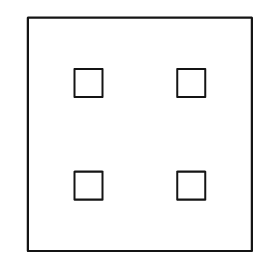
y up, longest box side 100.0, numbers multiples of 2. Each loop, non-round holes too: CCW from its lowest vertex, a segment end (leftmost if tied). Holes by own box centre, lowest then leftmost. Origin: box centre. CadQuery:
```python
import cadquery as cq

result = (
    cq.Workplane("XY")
    .moveTo(-48.0, -50.0)
    .lineTo(48.0, -50.0)
    .lineTo(48.0, 50.0)
    .lineTo(-48.0, 50.0)
    .close()
    .moveTo(-28.0, -28.0)
    .lineTo(-16.0, -28.0)
    .lineTo(-16.0, -16.0)
    .lineTo(-28.0, -16.0)
    .close()
    .moveTo(16.0, -28.0)
    .lineTo(28.0, -28.0)
    .lineTo(28.0, -16.0)
    .lineTo(16.0, -16.0)
    .close()
    .moveTo(-28.0, 16.0)
    .lineTo(-16.0, 16.0)
    .lineTo(-16.0, 28.0)
    .lineTo(-28.0, 28.0)
    .close()
    .moveTo(16.0, 16.0)
    .lineTo(28.0, 16.0)
    .lineTo(28.0, 28.0)
    .lineTo(16.0, 28.0)
    .close()
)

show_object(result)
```